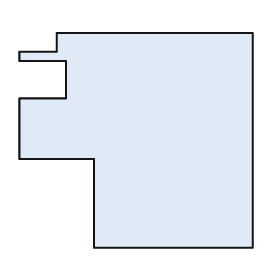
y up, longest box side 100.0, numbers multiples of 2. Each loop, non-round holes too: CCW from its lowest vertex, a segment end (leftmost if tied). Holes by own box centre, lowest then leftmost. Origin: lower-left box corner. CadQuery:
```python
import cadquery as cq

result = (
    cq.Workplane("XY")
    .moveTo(32.0, 0.0)
    .lineTo(100.0, 0.0)
    .lineTo(100.0, 92.0)
    .lineTo(16.0, 92.0)
    .lineTo(16.0, 84.0)
    .lineTo(0.0, 84.0)
    .lineTo(0.0, 80.0)
    .lineTo(20.0, 80.0)
    .lineTo(20.0, 64.0)
    .lineTo(0.0, 64.0)
    .lineTo(0.0, 38.0)
    .lineTo(32.0, 38.0)
    .close()
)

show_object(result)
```